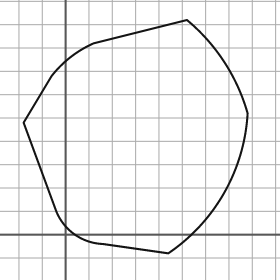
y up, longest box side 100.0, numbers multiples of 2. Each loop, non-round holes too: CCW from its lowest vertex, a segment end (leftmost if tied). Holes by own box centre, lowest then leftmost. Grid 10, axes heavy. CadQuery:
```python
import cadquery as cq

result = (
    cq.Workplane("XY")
    .moveTo(44.0, -8.0)
    .threePointArc((68.0, 18.0), (78.0, 52.0))
    .threePointArc((68.0, 74.0), (52.0, 92.0))
    .lineTo(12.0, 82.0)
    .threePointArc((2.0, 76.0), (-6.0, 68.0))
    .lineTo(-18.0, 48.0)
    .lineTo(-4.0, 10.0)
    .threePointArc((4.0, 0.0), (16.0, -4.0))
    .close()
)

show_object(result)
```